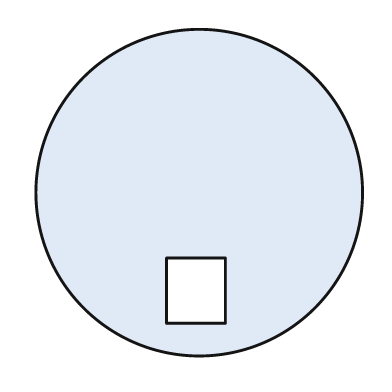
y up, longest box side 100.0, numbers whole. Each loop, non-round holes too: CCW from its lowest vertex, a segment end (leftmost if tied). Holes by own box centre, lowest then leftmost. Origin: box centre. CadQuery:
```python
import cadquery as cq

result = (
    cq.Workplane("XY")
    .moveTo(0.0, 0.0)
    .circle(50.0)
    .moveTo(-10.0, -40.0)
    .lineTo(8.0, -40.0)
    .lineTo(8.0, -20.0)
    .lineTo(-10.0, -20.0)
    .close()
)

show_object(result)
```